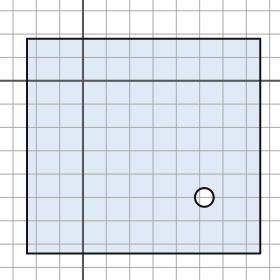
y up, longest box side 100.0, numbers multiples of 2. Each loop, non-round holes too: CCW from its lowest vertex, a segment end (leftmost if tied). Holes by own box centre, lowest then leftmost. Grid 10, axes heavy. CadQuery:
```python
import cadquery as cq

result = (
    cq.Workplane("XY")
    .moveTo(-24.0, -74.0)
    .lineTo(76.0, -74.0)
    .lineTo(76.0, 18.0)
    .lineTo(-24.0, 18.0)
    .close()
    .moveTo(52.0, -50.0)
    .circle(4.0)
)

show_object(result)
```